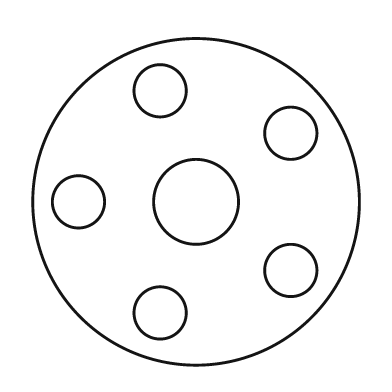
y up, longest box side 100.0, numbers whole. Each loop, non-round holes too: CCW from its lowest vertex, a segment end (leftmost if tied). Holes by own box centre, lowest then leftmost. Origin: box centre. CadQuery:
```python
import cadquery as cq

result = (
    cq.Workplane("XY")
    .moveTo(0.0, 0.0)
    .circle(50.0)
    .moveTo(-11.0, -34.0)
    .circle(8.0)
    .moveTo(29.0, -21.0)
    .circle(8.0)
    .moveTo(-36.0, 0.0)
    .circle(8.0)
    .moveTo(0.0, 0.0)
    .circle(13.0)
    .moveTo(29.0, 21.0)
    .circle(8.0)
    .moveTo(-11.0, 34.0)
    .circle(8.0)
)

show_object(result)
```